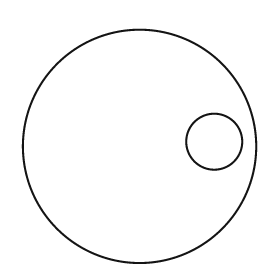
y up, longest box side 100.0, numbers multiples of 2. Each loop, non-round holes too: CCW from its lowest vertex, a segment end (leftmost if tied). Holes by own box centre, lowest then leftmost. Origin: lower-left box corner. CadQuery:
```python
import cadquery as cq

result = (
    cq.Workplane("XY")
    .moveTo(50.0, 50.0)
    .circle(50.0)
    .moveTo(82.0, 52.0)
    .circle(12.0)
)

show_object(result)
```